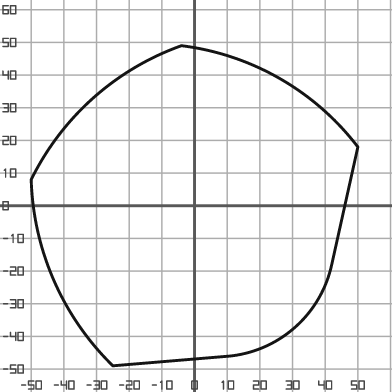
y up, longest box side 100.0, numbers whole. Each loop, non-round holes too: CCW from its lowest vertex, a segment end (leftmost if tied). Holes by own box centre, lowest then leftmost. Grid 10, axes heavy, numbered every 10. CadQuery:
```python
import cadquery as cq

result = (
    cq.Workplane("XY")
    .moveTo(-25.0, -49.0)
    .lineTo(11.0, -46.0)
    .threePointArc((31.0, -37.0), (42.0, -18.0))
    .lineTo(50.0, 18.0)
    .threePointArc((26.0, 39.0), (-4.0, 49.0))
    .threePointArc((-31.0, 33.0), (-50.0, 8.0))
    .threePointArc((-43.0, -23.0), (-25.0, -49.0))
    .close()
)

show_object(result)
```